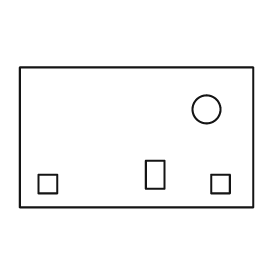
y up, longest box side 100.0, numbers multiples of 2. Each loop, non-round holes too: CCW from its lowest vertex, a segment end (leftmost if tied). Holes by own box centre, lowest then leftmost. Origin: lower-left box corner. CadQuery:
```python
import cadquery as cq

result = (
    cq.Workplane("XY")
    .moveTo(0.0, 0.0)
    .lineTo(100.0, 0.0)
    .lineTo(100.0, 60.0)
    .lineTo(0.0, 60.0)
    .close()
    .moveTo(8.0, 6.0)
    .lineTo(16.0, 6.0)
    .lineTo(16.0, 14.0)
    .lineTo(8.0, 14.0)
    .close()
    .moveTo(82.0, 6.0)
    .lineTo(90.0, 6.0)
    .lineTo(90.0, 14.0)
    .lineTo(82.0, 14.0)
    .close()
    .moveTo(54.0, 8.0)
    .lineTo(62.0, 8.0)
    .lineTo(62.0, 20.0)
    .lineTo(54.0, 20.0)
    .close()
    .moveTo(80.0, 42.0)
    .circle(6.0)
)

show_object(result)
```